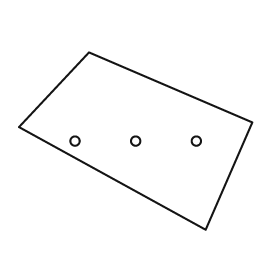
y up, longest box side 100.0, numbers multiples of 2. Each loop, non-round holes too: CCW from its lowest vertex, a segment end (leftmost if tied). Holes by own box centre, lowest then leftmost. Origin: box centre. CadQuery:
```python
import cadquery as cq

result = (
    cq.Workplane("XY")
    .moveTo(30.0, -38.0)
    .lineTo(50.0, 8.0)
    .lineTo(-20.0, 38.0)
    .lineTo(-50.0, 6.0)
    .close()
    .moveTo(-26.0, 0.0)
    .circle(2.0)
    .moveTo(0.0, 0.0)
    .circle(2.0)
    .moveTo(26.0, 0.0)
    .circle(2.0)
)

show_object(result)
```